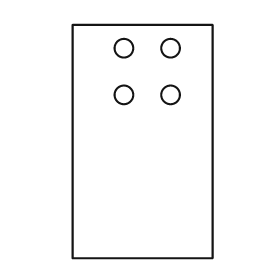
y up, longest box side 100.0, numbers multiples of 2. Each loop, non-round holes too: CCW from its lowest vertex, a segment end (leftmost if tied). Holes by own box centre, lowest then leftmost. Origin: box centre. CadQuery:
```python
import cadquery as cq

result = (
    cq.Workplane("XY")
    .moveTo(-30.0, -50.0)
    .lineTo(30.0, -50.0)
    .lineTo(30.0, 50.0)
    .lineTo(-30.0, 50.0)
    .close()
    .moveTo(-8.0, 20.0)
    .circle(4.0)
    .moveTo(12.0, 20.0)
    .circle(4.0)
    .moveTo(-8.0, 40.0)
    .circle(4.0)
    .moveTo(12.0, 40.0)
    .circle(4.0)
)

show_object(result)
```